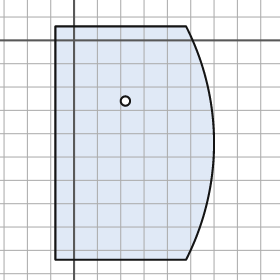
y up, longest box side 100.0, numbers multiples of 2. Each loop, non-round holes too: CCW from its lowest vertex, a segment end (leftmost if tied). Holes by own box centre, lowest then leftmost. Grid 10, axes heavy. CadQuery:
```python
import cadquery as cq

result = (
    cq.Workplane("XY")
    .moveTo(-8.0, -94.0)
    .lineTo(48.0, -94.0)
    .threePointArc((60.0, -44.0), (48.0, 6.0))
    .lineTo(-8.0, 6.0)
    .close()
    .moveTo(22.0, -26.0)
    .circle(2.0)
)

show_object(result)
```